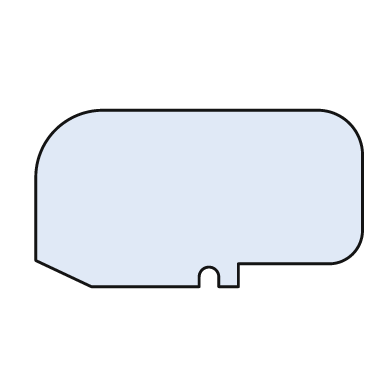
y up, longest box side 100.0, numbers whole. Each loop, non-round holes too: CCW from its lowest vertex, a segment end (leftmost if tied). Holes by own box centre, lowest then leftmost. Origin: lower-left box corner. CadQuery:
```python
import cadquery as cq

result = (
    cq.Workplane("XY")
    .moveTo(17.0, 0.0)
    .lineTo(50.0, 0.0)
    .lineTo(50.0, 3.0)
    .threePointArc((53.0, 6.0), (56.0, 3.0))
    .lineTo(56.0, 0.0)
    .lineTo(62.0, 0.0)
    .lineTo(62.0, 7.0)
    .lineTo(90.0, 7.0)
    .threePointArc((97.0, 10.0), (100.0, 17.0))
    .lineTo(100.0, 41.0)
    .threePointArc((96.0, 50.0), (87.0, 54.0))
    .lineTo(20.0, 54.0)
    .threePointArc((6.0, 48.0), (0.0, 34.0))
    .lineTo(0.0, 8.0)
    .close()
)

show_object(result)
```